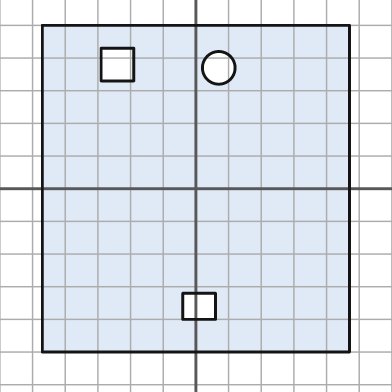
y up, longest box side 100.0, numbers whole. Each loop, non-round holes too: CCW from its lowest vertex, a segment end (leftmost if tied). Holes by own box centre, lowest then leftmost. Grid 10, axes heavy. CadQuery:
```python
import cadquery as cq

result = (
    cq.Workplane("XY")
    .moveTo(-47.0, -50.0)
    .lineTo(47.0, -50.0)
    .lineTo(47.0, 50.0)
    .lineTo(-47.0, 50.0)
    .close()
    .moveTo(-4.0, -40.0)
    .lineTo(6.0, -40.0)
    .lineTo(6.0, -32.0)
    .lineTo(-4.0, -32.0)
    .close()
    .moveTo(7.0, 37.0)
    .circle(5.0)
    .moveTo(-29.0, 33.0)
    .lineTo(-19.0, 33.0)
    .lineTo(-19.0, 43.0)
    .lineTo(-29.0, 43.0)
    .close()
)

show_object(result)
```